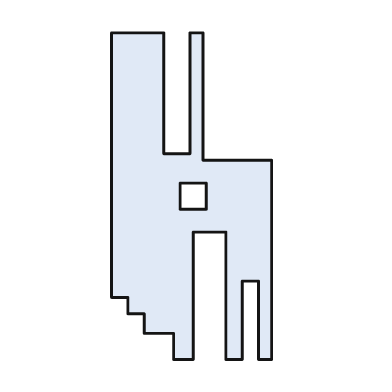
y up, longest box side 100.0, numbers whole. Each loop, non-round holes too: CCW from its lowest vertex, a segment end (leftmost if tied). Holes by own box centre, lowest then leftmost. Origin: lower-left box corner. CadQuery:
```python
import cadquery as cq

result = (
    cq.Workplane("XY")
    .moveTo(19.0, 0.0)
    .lineTo(25.0, 0.0)
    .lineTo(25.0, 39.0)
    .lineTo(35.0, 39.0)
    .lineTo(35.0, 0.0)
    .lineTo(40.0, 0.0)
    .lineTo(40.0, 24.0)
    .lineTo(45.0, 24.0)
    .lineTo(45.0, 0.0)
    .lineTo(49.0, 0.0)
    .lineTo(49.0, 61.0)
    .lineTo(28.0, 61.0)
    .lineTo(28.0, 100.0)
    .lineTo(24.0, 100.0)
    .lineTo(24.0, 63.0)
    .lineTo(16.0, 63.0)
    .lineTo(16.0, 100.0)
    .lineTo(0.0, 100.0)
    .lineTo(0.0, 19.0)
    .lineTo(5.0, 19.0)
    .lineTo(5.0, 14.0)
    .lineTo(10.0, 14.0)
    .lineTo(10.0, 8.0)
    .lineTo(19.0, 8.0)
    .close()
    .moveTo(21.0, 46.0)
    .lineTo(29.0, 46.0)
    .lineTo(29.0, 54.0)
    .lineTo(21.0, 54.0)
    .close()
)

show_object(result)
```